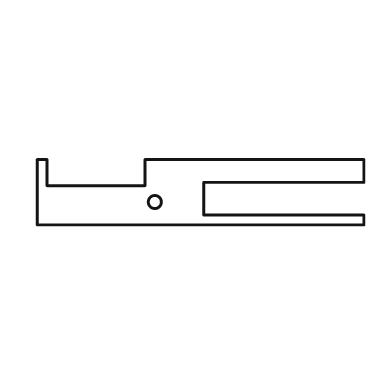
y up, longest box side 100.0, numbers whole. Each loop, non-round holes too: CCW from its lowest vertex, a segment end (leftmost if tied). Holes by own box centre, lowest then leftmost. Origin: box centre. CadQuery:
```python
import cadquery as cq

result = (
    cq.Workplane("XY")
    .moveTo(-50.0, -10.0)
    .lineTo(50.0, -10.0)
    .lineTo(50.0, -7.0)
    .lineTo(1.0, -7.0)
    .lineTo(1.0, 3.0)
    .lineTo(50.0, 3.0)
    .lineTo(50.0, 10.0)
    .lineTo(-17.0, 10.0)
    .lineTo(-17.0, 2.0)
    .lineTo(-47.0, 2.0)
    .lineTo(-47.0, 10.0)
    .lineTo(-50.0, 10.0)
    .close()
    .moveTo(-14.0, -3.0)
    .circle(2.0)
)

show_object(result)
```